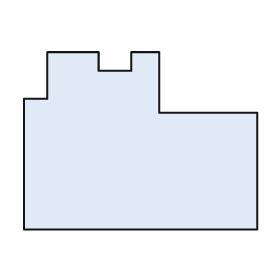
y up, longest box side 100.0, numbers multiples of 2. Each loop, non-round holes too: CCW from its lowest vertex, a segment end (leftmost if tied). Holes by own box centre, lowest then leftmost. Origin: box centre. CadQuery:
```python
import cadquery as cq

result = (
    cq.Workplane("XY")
    .moveTo(-50.0, -38.0)
    .lineTo(50.0, -38.0)
    .lineTo(50.0, 12.0)
    .lineTo(8.0, 12.0)
    .lineTo(8.0, 38.0)
    .lineTo(-4.0, 38.0)
    .lineTo(-4.0, 30.0)
    .lineTo(-18.0, 30.0)
    .lineTo(-18.0, 38.0)
    .lineTo(-40.0, 38.0)
    .lineTo(-40.0, 18.0)
    .lineTo(-50.0, 18.0)
    .close()
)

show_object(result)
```